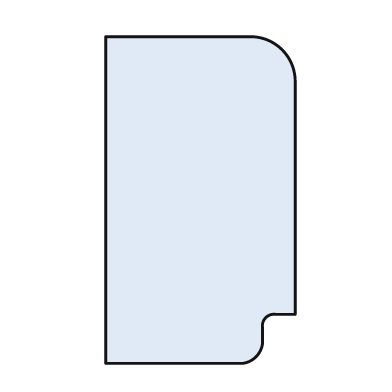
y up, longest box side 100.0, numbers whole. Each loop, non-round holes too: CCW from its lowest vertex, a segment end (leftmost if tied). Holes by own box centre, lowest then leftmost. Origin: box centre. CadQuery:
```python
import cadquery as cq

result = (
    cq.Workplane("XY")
    .moveTo(-29.0, -50.0)
    .lineTo(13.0, -50.0)
    .threePointArc((17.0, -48.0), (19.0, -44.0))
    .lineTo(19.0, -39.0)
    .threePointArc((20.0, -36.0), (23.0, -35.0))
    .lineTo(29.0, -35.0)
    .lineTo(29.0, 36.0)
    .threePointArc((25.0, 46.0), (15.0, 50.0))
    .lineTo(-29.0, 50.0)
    .close()
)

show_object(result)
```